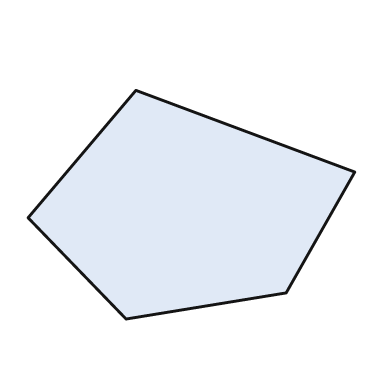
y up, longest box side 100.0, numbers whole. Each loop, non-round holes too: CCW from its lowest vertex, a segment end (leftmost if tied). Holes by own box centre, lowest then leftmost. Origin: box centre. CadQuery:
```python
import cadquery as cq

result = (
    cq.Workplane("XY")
    .moveTo(-20.0, -35.0)
    .lineTo(29.0, -27.0)
    .lineTo(50.0, 10.0)
    .lineTo(-17.0, 35.0)
    .lineTo(-50.0, -4.0)
    .close()
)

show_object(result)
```